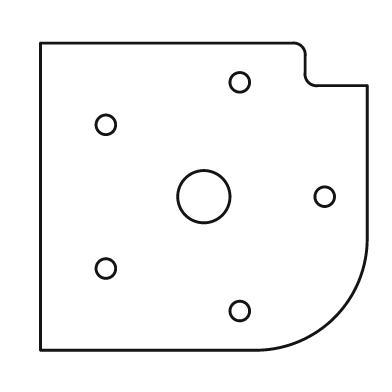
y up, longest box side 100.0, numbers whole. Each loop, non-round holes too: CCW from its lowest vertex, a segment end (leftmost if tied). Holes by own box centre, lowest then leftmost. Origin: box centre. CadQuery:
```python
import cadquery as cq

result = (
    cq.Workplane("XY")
    .moveTo(-50.0, -47.0)
    .lineTo(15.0, -47.0)
    .threePointArc((40.0, -37.0), (50.0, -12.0))
    .lineTo(50.0, 34.0)
    .lineTo(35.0, 34.0)
    .threePointArc((32.0, 35.0), (31.0, 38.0))
    .lineTo(31.0, 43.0)
    .threePointArc((30.0, 46.0), (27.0, 47.0))
    .lineTo(-50.0, 47.0)
    .close()
    .moveTo(11.0, -35.0)
    .circle(3.0)
    .moveTo(-30.0, -22.0)
    .circle(3.0)
    .moveTo(0.0, 0.0)
    .circle(8.0)
    .moveTo(37.0, 0.0)
    .circle(3.0)
    .moveTo(-30.0, 22.0)
    .circle(3.0)
    .moveTo(11.0, 35.0)
    .circle(3.0)
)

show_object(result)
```